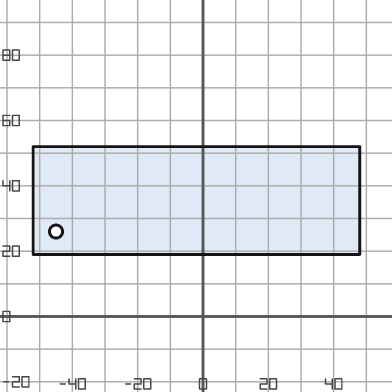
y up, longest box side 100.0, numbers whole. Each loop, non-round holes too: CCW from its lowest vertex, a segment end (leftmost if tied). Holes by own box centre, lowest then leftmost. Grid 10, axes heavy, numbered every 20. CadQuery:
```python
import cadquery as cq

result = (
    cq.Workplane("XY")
    .moveTo(-52.0, 19.0)
    .lineTo(48.0, 19.0)
    .lineTo(48.0, 52.0)
    .lineTo(-52.0, 52.0)
    .close()
    .moveTo(-45.0, 26.0)
    .circle(2.0)
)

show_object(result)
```